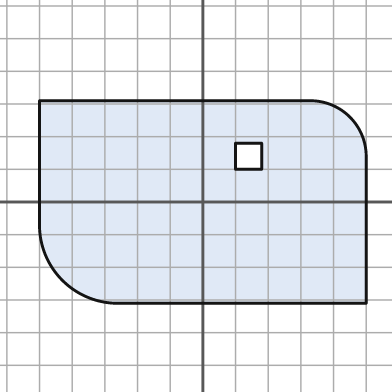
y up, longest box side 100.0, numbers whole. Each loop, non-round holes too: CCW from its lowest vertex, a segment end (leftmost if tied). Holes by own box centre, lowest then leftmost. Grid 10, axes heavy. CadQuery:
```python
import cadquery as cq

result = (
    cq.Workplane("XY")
    .moveTo(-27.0, -31.0)
    .lineTo(50.0, -31.0)
    .lineTo(50.0, 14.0)
    .threePointArc((45.0, 26.0), (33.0, 31.0))
    .lineTo(-50.0, 31.0)
    .lineTo(-50.0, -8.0)
    .threePointArc((-43.0, -24.0), (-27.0, -31.0))
    .close()
    .moveTo(10.0, 10.0)
    .lineTo(18.0, 10.0)
    .lineTo(18.0, 18.0)
    .lineTo(10.0, 18.0)
    .close()
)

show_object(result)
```